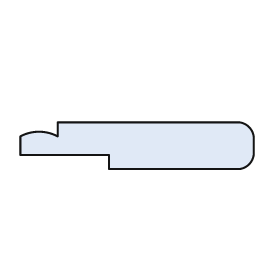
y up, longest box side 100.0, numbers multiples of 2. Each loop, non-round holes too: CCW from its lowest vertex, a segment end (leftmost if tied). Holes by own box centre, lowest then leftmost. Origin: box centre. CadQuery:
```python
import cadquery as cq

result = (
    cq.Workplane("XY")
    .moveTo(-12.0, -10.0)
    .lineTo(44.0, -10.0)
    .threePointArc((48.0, -8.0), (50.0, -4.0))
    .lineTo(50.0, 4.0)
    .threePointArc((48.0, 8.0), (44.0, 10.0))
    .lineTo(-34.0, 10.0)
    .lineTo(-34.0, 4.0)
    .threePointArc((-42.0, 6.0), (-50.0, 4.0))
    .lineTo(-50.0, -4.0)
    .lineTo(-12.0, -4.0)
    .close()
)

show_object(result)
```